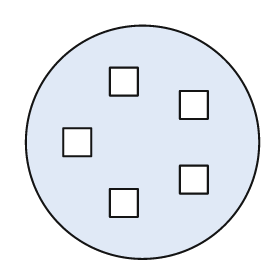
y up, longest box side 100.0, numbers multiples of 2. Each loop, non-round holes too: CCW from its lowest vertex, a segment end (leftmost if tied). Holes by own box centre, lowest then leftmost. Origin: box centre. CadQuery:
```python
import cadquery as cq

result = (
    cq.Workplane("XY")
    .moveTo(0.0, 0.0)
    .circle(50.0)
    .moveTo(-14.0, -32.0)
    .lineTo(-2.0, -32.0)
    .lineTo(-2.0, -20.0)
    .lineTo(-14.0, -20.0)
    .close()
    .moveTo(16.0, -22.0)
    .lineTo(28.0, -22.0)
    .lineTo(28.0, -10.0)
    .lineTo(16.0, -10.0)
    .close()
    .moveTo(-34.0, -6.0)
    .lineTo(-22.0, -6.0)
    .lineTo(-22.0, 6.0)
    .lineTo(-34.0, 6.0)
    .close()
    .moveTo(16.0, 10.0)
    .lineTo(28.0, 10.0)
    .lineTo(28.0, 22.0)
    .lineTo(16.0, 22.0)
    .close()
    .moveTo(-14.0, 20.0)
    .lineTo(-2.0, 20.0)
    .lineTo(-2.0, 32.0)
    .lineTo(-14.0, 32.0)
    .close()
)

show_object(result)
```